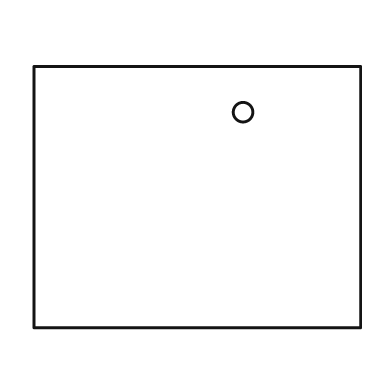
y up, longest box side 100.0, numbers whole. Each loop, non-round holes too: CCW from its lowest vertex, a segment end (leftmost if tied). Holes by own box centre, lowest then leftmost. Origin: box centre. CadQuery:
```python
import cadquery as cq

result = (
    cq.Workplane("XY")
    .moveTo(-50.0, -40.0)
    .lineTo(50.0, -40.0)
    .lineTo(50.0, 40.0)
    .lineTo(-50.0, 40.0)
    .close()
    .moveTo(14.0, 26.0)
    .circle(3.0)
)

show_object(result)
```